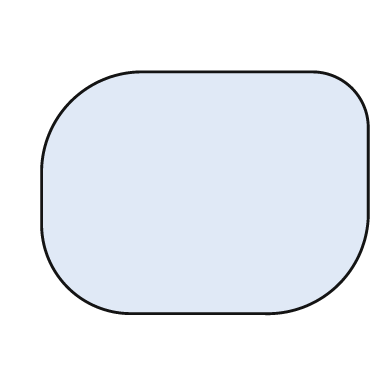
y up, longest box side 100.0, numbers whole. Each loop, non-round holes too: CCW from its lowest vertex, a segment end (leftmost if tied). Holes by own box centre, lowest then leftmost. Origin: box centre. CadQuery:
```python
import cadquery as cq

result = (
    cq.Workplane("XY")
    .moveTo(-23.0, -37.0)
    .lineTo(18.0, -37.0)
    .threePointArc((41.0, -28.0), (50.0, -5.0))
    .lineTo(50.0, 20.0)
    .threePointArc((45.0, 32.0), (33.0, 37.0))
    .lineTo(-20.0, 37.0)
    .threePointArc((-41.0, 28.0), (-50.0, 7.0))
    .lineTo(-50.0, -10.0)
    .threePointArc((-42.0, -29.0), (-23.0, -37.0))
    .close()
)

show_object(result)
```